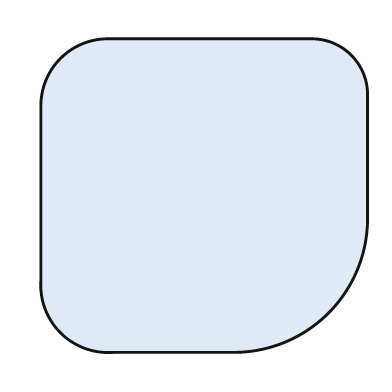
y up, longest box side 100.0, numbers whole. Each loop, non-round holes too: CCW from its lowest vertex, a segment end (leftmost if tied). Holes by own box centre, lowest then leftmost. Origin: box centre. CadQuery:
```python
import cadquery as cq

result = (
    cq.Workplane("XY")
    .moveTo(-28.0, -48.0)
    .lineTo(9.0, -48.0)
    .threePointArc((38.0, -36.0), (50.0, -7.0))
    .lineTo(50.0, 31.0)
    .threePointArc((45.0, 43.0), (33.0, 48.0))
    .lineTo(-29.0, 48.0)
    .threePointArc((-44.0, 42.0), (-50.0, 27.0))
    .lineTo(-50.0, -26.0)
    .threePointArc((-44.0, -42.0), (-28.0, -48.0))
    .close()
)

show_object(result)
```